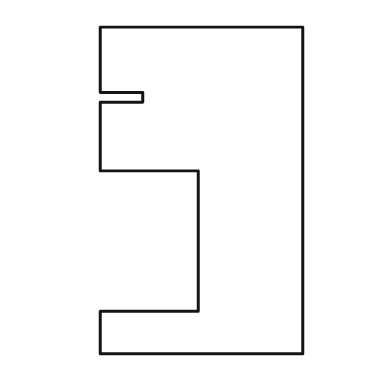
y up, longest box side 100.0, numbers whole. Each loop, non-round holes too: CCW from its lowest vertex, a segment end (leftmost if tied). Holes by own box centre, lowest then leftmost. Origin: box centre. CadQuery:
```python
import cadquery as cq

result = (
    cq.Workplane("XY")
    .moveTo(-31.0, -50.0)
    .lineTo(31.0, -50.0)
    .lineTo(31.0, 50.0)
    .lineTo(-31.0, 50.0)
    .lineTo(-31.0, 30.0)
    .lineTo(-18.0, 30.0)
    .lineTo(-18.0, 27.0)
    .lineTo(-31.0, 27.0)
    .lineTo(-31.0, 6.0)
    .lineTo(-1.0, 6.0)
    .lineTo(-1.0, -37.0)
    .lineTo(-31.0, -37.0)
    .close()
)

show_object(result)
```